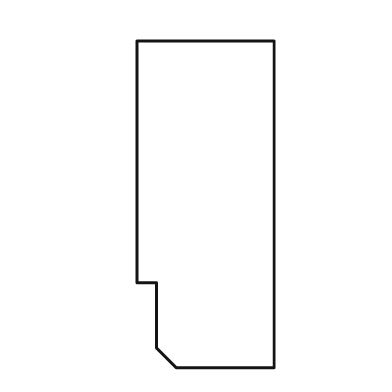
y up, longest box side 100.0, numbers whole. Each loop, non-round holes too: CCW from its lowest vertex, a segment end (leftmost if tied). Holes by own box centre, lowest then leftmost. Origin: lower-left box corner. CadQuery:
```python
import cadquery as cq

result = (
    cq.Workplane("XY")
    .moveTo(12.0, 0.0)
    .lineTo(42.0, 0.0)
    .lineTo(42.0, 100.0)
    .lineTo(0.0, 100.0)
    .lineTo(0.0, 26.0)
    .lineTo(6.0, 26.0)
    .lineTo(6.0, 6.0)
    .close()
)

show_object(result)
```